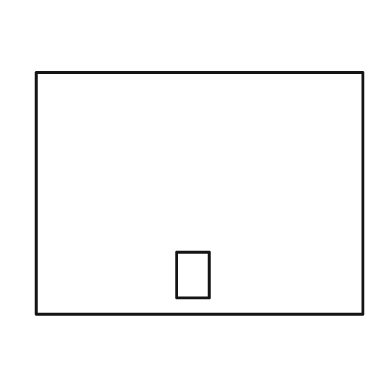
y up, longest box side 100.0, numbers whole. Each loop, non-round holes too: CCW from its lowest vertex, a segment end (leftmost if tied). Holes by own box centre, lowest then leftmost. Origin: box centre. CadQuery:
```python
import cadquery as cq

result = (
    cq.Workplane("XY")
    .moveTo(-50.0, -37.0)
    .lineTo(50.0, -37.0)
    .lineTo(50.0, 37.0)
    .lineTo(-50.0, 37.0)
    .close()
    .moveTo(-7.0, -32.0)
    .lineTo(3.0, -32.0)
    .lineTo(3.0, -18.0)
    .lineTo(-7.0, -18.0)
    .close()
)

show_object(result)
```